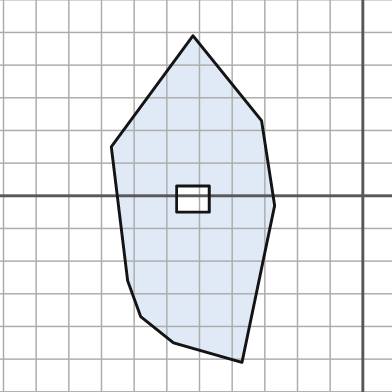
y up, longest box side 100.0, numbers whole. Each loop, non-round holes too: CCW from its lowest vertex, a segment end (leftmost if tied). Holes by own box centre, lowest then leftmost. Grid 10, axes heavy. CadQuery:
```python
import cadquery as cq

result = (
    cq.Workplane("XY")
    .moveTo(-37.0, -51.0)
    .lineTo(-27.0, -3.0)
    .lineTo(-31.0, 23.0)
    .lineTo(-52.0, 49.0)
    .lineTo(-77.0, 15.0)
    .lineTo(-72.0, -26.0)
    .lineTo(-68.0, -37.0)
    .lineTo(-58.0, -45.0)
    .close()
    .moveTo(-57.0, -5.0)
    .lineTo(-47.0, -5.0)
    .lineTo(-47.0, 3.0)
    .lineTo(-57.0, 3.0)
    .close()
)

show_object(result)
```